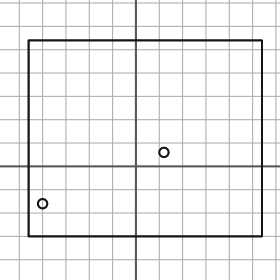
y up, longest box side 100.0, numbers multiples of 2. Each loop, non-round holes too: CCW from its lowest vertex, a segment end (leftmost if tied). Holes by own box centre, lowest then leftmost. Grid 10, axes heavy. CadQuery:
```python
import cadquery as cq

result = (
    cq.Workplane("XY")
    .moveTo(-46.0, -30.0)
    .lineTo(54.0, -30.0)
    .lineTo(54.0, 54.0)
    .lineTo(-46.0, 54.0)
    .close()
    .moveTo(-40.0, -16.0)
    .circle(2.0)
    .moveTo(12.0, 6.0)
    .circle(2.0)
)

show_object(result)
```